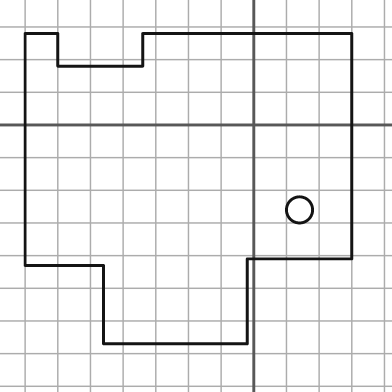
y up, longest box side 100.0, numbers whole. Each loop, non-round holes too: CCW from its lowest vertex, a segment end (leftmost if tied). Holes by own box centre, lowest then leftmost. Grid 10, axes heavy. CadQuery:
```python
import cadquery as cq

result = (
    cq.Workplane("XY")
    .moveTo(-46.0, -67.0)
    .lineTo(-2.0, -67.0)
    .lineTo(-2.0, -41.0)
    .lineTo(30.0, -41.0)
    .lineTo(30.0, 28.0)
    .lineTo(-34.0, 28.0)
    .lineTo(-34.0, 18.0)
    .lineTo(-60.0, 18.0)
    .lineTo(-60.0, 28.0)
    .lineTo(-70.0, 28.0)
    .lineTo(-70.0, -43.0)
    .lineTo(-46.0, -43.0)
    .close()
    .moveTo(14.0, -26.0)
    .circle(4.0)
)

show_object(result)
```